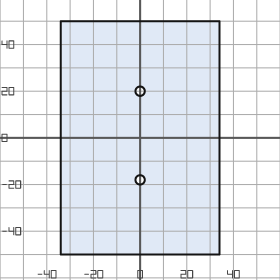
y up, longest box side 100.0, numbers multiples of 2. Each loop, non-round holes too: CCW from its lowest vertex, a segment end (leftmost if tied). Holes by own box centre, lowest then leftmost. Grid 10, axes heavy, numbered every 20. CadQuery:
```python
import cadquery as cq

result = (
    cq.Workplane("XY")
    .moveTo(-34.0, -50.0)
    .lineTo(34.0, -50.0)
    .lineTo(34.0, 50.0)
    .lineTo(-34.0, 50.0)
    .close()
    .moveTo(0.0, -18.0)
    .circle(2.0)
    .moveTo(0.0, 20.0)
    .circle(2.0)
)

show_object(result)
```